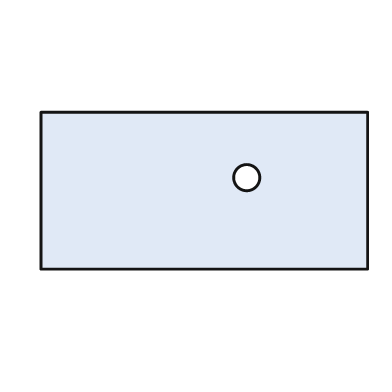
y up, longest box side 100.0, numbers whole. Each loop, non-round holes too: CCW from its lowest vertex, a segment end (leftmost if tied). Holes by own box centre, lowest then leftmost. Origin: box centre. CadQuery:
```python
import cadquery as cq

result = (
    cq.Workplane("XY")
    .moveTo(-50.0, -24.0)
    .lineTo(50.0, -24.0)
    .lineTo(50.0, 24.0)
    .lineTo(-50.0, 24.0)
    .close()
    .moveTo(13.0, 4.0)
    .circle(4.0)
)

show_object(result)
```